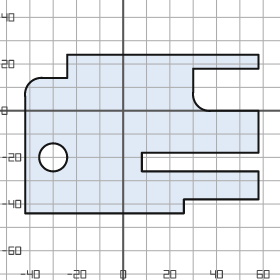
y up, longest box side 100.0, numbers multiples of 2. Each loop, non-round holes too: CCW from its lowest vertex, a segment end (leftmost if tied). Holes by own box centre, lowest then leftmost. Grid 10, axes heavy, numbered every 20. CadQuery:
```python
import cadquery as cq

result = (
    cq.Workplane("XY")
    .moveTo(-42.0, -44.0)
    .lineTo(26.0, -44.0)
    .lineTo(26.0, -38.0)
    .lineTo(58.0, -38.0)
    .lineTo(58.0, -26.0)
    .lineTo(8.0, -26.0)
    .lineTo(8.0, -18.0)
    .lineTo(58.0, -18.0)
    .lineTo(58.0, 0.0)
    .lineTo(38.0, 0.0)
    .threePointArc((32.0, 2.0), (30.0, 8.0))
    .lineTo(30.0, 18.0)
    .lineTo(58.0, 18.0)
    .lineTo(58.0, 24.0)
    .lineTo(-24.0, 24.0)
    .lineTo(-24.0, 14.0)
    .lineTo(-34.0, 14.0)
    .threePointArc((-40.0, 12.0), (-42.0, 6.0))
    .close()
    .moveTo(-30.0, -20.0)
    .circle(6.0)
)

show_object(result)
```